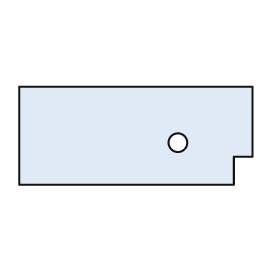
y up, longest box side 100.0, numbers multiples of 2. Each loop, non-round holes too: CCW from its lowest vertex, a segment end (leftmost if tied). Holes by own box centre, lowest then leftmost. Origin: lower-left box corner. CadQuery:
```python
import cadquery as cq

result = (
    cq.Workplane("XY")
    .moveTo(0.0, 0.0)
    .lineTo(92.0, 0.0)
    .lineTo(92.0, 12.0)
    .lineTo(100.0, 12.0)
    .lineTo(100.0, 42.0)
    .lineTo(0.0, 42.0)
    .close()
    .moveTo(68.0, 18.0)
    .circle(4.0)
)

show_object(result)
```